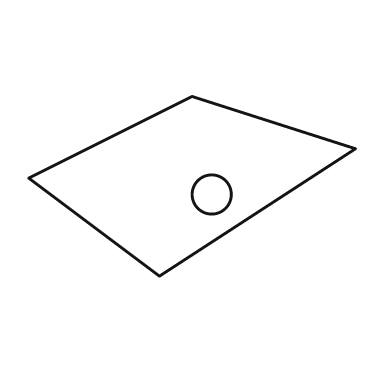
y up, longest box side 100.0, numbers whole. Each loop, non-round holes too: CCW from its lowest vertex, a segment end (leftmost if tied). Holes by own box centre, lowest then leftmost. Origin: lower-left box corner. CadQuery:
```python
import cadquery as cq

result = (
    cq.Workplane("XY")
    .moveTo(40.0, 0.0)
    .lineTo(100.0, 39.0)
    .lineTo(50.0, 55.0)
    .lineTo(0.0, 30.0)
    .close()
    .moveTo(56.0, 25.0)
    .circle(6.0)
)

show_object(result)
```